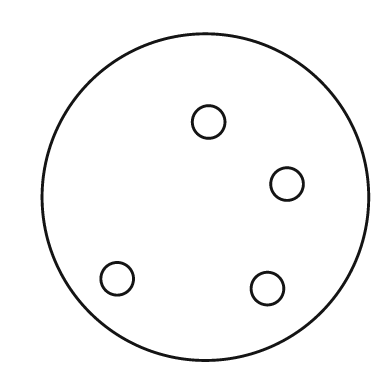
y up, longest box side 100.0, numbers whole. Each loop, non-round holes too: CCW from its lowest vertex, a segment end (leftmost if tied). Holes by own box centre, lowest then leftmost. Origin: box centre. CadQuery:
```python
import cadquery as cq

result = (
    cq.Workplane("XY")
    .moveTo(0.0, 0.0)
    .circle(50.0)
    .moveTo(19.0, -28.0)
    .circle(5.0)
    .moveTo(-27.0, -25.0)
    .circle(5.0)
    .moveTo(25.0, 4.0)
    .circle(5.0)
    .moveTo(1.0, 23.0)
    .circle(5.0)
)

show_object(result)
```